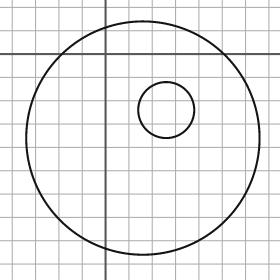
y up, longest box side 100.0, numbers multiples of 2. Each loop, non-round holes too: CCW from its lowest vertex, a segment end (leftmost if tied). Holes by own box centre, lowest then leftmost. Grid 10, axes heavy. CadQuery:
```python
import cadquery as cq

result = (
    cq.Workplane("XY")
    .moveTo(16.0, -36.0)
    .circle(50.0)
    .moveTo(26.0, -24.0)
    .circle(12.0)
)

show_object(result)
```